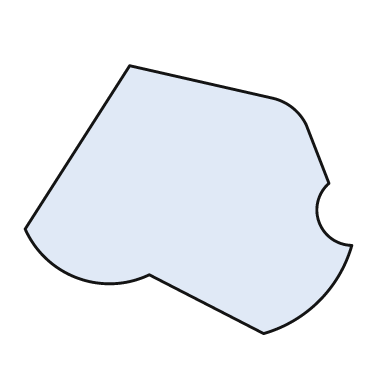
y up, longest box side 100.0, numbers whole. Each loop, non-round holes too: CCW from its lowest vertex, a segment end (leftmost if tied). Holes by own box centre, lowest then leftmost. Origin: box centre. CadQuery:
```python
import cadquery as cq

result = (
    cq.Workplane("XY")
    .moveTo(23.0, -41.0)
    .threePointArc((40.0, -31.0), (50.0, -14.0))
    .threePointArc((40.0, -7.0), (43.0, 5.0))
    .lineTo(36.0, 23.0)
    .threePointArc((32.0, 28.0), (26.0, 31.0))
    .lineTo(-18.0, 41.0)
    .lineTo(-50.0, -9.0)
    .threePointArc((-34.0, -24.0), (-12.0, -23.0))
    .close()
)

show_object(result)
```